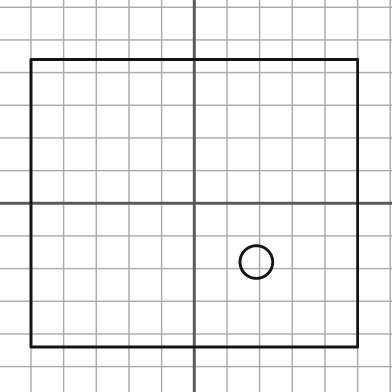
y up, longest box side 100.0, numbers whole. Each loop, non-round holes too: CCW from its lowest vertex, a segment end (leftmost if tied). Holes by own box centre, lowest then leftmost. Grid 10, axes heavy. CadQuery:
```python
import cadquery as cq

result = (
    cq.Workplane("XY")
    .moveTo(-50.0, -44.0)
    .lineTo(50.0, -44.0)
    .lineTo(50.0, 44.0)
    .lineTo(-50.0, 44.0)
    .close()
    .moveTo(19.0, -18.0)
    .circle(5.0)
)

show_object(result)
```